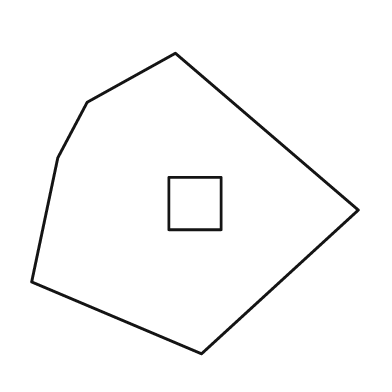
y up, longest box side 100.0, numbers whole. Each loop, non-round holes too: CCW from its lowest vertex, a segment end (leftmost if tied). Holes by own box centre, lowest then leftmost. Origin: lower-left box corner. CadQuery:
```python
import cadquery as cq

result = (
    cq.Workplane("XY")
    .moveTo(52.0, 0.0)
    .lineTo(100.0, 44.0)
    .lineTo(44.0, 92.0)
    .lineTo(17.0, 77.0)
    .lineTo(8.0, 60.0)
    .lineTo(0.0, 22.0)
    .close()
    .moveTo(42.0, 38.0)
    .lineTo(58.0, 38.0)
    .lineTo(58.0, 54.0)
    .lineTo(42.0, 54.0)
    .close()
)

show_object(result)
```